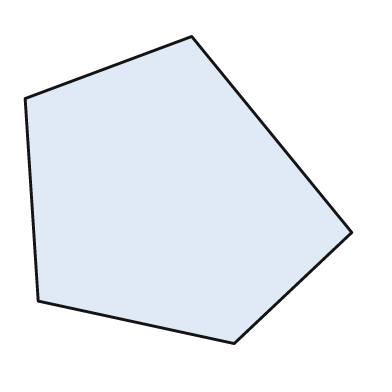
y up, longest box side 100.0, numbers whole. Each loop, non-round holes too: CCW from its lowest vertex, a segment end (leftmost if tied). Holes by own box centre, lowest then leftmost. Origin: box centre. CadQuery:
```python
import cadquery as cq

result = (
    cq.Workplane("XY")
    .moveTo(14.0, -47.0)
    .lineTo(50.0, -13.0)
    .lineTo(1.0, 47.0)
    .lineTo(-50.0, 28.0)
    .lineTo(-46.0, -34.0)
    .close()
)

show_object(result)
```